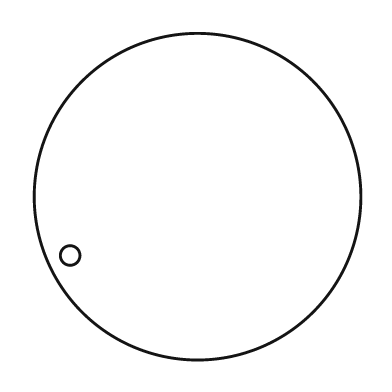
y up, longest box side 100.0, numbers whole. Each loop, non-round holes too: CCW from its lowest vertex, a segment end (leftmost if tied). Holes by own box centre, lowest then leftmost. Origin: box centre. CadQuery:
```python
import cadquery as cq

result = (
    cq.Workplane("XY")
    .moveTo(0.0, 0.0)
    .circle(50.0)
    .moveTo(-39.0, -18.0)
    .circle(3.0)
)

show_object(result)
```